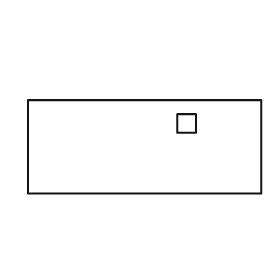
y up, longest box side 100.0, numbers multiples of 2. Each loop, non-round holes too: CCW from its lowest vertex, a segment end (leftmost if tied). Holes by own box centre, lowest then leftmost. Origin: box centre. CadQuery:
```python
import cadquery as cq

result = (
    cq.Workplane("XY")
    .moveTo(-50.0, -20.0)
    .lineTo(50.0, -20.0)
    .lineTo(50.0, 20.0)
    .lineTo(-50.0, 20.0)
    .close()
    .moveTo(14.0, 6.0)
    .lineTo(22.0, 6.0)
    .lineTo(22.0, 14.0)
    .lineTo(14.0, 14.0)
    .close()
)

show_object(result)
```